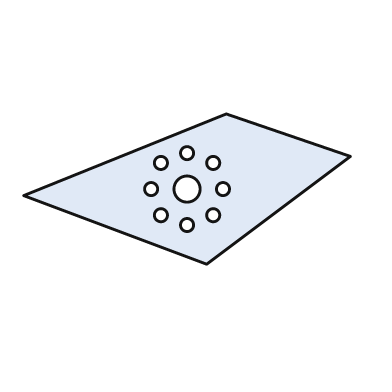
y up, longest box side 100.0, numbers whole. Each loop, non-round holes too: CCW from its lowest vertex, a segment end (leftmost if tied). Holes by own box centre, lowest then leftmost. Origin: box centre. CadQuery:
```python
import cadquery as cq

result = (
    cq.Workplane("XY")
    .moveTo(6.0, -23.0)
    .lineTo(50.0, 10.0)
    .lineTo(12.0, 23.0)
    .lineTo(-50.0, -2.0)
    .close()
    .moveTo(0.0, -11.0)
    .circle(2.0)
    .moveTo(-8.0, -8.0)
    .circle(2.0)
    .moveTo(8.0, -8.0)
    .circle(2.0)
    .moveTo(-11.0, 0.0)
    .circle(2.0)
    .moveTo(0.0, 0.0)
    .circle(4.0)
    .moveTo(11.0, 0.0)
    .circle(2.0)
    .moveTo(-8.0, 8.0)
    .circle(2.0)
    .moveTo(8.0, 8.0)
    .circle(2.0)
    .moveTo(0.0, 11.0)
    .circle(2.0)
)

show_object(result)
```